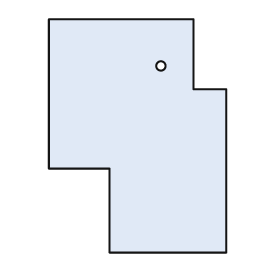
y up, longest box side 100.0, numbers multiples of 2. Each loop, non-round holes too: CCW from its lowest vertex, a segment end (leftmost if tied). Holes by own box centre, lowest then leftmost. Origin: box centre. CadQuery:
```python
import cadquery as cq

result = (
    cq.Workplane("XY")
    .moveTo(-12.0, -50.0)
    .lineTo(38.0, -50.0)
    .lineTo(38.0, 20.0)
    .lineTo(24.0, 20.0)
    .lineTo(24.0, 50.0)
    .lineTo(-38.0, 50.0)
    .lineTo(-38.0, -14.0)
    .lineTo(-12.0, -14.0)
    .close()
    .moveTo(10.0, 30.0)
    .circle(2.0)
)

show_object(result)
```